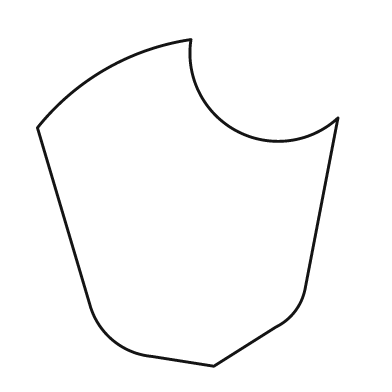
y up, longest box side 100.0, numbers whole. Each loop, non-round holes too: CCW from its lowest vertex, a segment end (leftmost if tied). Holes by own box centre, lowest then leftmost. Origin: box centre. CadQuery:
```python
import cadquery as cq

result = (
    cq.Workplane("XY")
    .moveTo(8.0, -50.0)
    .lineTo(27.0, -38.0)
    .threePointArc((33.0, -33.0), (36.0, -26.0))
    .lineTo(46.0, 26.0)
    .threePointArc((15.0, 22.0), (1.0, 50.0))
    .threePointArc((-25.0, 41.0), (-46.0, 23.0))
    .lineTo(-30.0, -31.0)
    .threePointArc((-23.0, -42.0), (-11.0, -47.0))
    .close()
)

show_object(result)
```